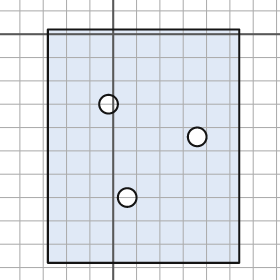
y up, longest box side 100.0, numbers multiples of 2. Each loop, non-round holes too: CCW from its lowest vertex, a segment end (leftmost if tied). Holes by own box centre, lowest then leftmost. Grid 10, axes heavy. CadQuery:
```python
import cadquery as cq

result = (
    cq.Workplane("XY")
    .moveTo(-28.0, -98.0)
    .lineTo(54.0, -98.0)
    .lineTo(54.0, 2.0)
    .lineTo(-28.0, 2.0)
    .close()
    .moveTo(6.0, -70.0)
    .circle(4.0)
    .moveTo(36.0, -44.0)
    .circle(4.0)
    .moveTo(-2.0, -30.0)
    .circle(4.0)
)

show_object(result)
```